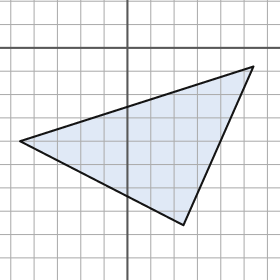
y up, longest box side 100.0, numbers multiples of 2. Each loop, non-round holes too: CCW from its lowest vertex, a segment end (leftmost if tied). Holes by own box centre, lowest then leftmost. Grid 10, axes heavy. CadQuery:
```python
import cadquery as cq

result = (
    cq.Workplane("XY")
    .moveTo(24.0, -76.0)
    .lineTo(54.0, -8.0)
    .lineTo(-46.0, -40.0)
    .close()
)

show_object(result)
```